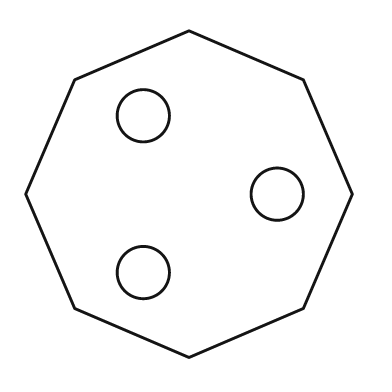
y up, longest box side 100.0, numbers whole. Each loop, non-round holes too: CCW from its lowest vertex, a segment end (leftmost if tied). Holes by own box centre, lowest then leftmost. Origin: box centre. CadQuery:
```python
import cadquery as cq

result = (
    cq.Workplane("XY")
    .moveTo(0.0, -50.0)
    .lineTo(35.0, -35.0)
    .lineTo(50.0, 0.0)
    .lineTo(35.0, 35.0)
    .lineTo(0.0, 50.0)
    .lineTo(-35.0, 35.0)
    .lineTo(-50.0, 0.0)
    .lineTo(-35.0, -35.0)
    .close()
    .moveTo(-14.0, -24.0)
    .circle(8.0)
    .moveTo(27.0, 0.0)
    .circle(8.0)
    .moveTo(-14.0, 24.0)
    .circle(8.0)
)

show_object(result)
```